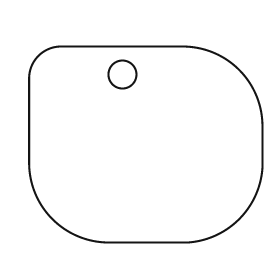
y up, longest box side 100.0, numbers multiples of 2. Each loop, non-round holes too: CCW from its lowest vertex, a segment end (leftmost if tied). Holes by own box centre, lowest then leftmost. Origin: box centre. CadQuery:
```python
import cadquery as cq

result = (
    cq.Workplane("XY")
    .moveTo(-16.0, -42.0)
    .lineTo(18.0, -42.0)
    .threePointArc((40.0, -32.0), (50.0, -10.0))
    .lineTo(50.0, 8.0)
    .threePointArc((40.0, 32.0), (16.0, 42.0))
    .lineTo(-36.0, 42.0)
    .threePointArc((-46.0, 38.0), (-50.0, 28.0))
    .lineTo(-50.0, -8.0)
    .threePointArc((-40.0, -32.0), (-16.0, -42.0))
    .close()
    .moveTo(-10.0, 30.0)
    .circle(6.0)
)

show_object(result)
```